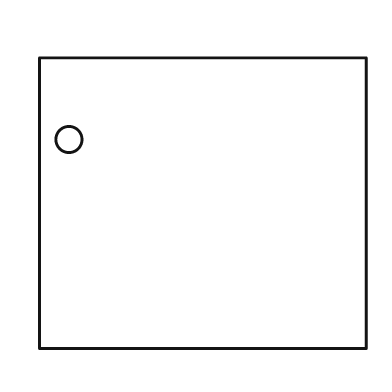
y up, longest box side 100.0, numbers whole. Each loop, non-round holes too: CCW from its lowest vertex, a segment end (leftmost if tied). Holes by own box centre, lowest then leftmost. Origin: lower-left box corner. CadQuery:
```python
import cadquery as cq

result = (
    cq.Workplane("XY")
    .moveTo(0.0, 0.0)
    .lineTo(100.0, 0.0)
    .lineTo(100.0, 89.0)
    .lineTo(0.0, 89.0)
    .close()
    .moveTo(9.0, 64.0)
    .circle(4.0)
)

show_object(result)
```